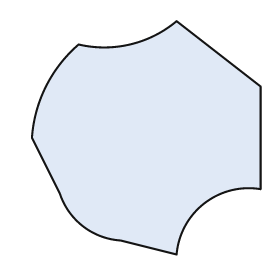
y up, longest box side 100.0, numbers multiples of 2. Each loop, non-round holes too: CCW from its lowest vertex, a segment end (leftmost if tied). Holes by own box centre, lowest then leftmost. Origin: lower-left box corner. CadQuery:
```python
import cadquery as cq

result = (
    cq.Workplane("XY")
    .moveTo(62.0, 0.0)
    .threePointArc((74.0, 22.0), (98.0, 28.0))
    .lineTo(98.0, 72.0)
    .lineTo(62.0, 100.0)
    .threePointArc((42.0, 90.0), (20.0, 90.0))
    .threePointArc((6.0, 72.0), (0.0, 50.0))
    .lineTo(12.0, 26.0)
    .threePointArc((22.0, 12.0), (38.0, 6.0))
    .close()
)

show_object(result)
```